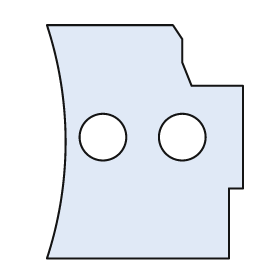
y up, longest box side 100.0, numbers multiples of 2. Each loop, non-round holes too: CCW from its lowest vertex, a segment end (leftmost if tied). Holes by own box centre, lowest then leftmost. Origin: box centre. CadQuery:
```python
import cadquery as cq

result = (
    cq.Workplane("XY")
    .moveTo(-42.0, -50.0)
    .lineTo(36.0, -50.0)
    .lineTo(36.0, -20.0)
    .lineTo(42.0, -20.0)
    .lineTo(42.0, 24.0)
    .lineTo(20.0, 24.0)
    .lineTo(16.0, 34.0)
    .lineTo(16.0, 44.0)
    .lineTo(12.0, 50.0)
    .lineTo(-42.0, 50.0)
    .threePointArc((-34.0, 0.0), (-42.0, -50.0))
    .close()
    .moveTo(-18.0, 2.0)
    .circle(10.0)
    .moveTo(16.0, 2.0)
    .circle(10.0)
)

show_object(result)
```